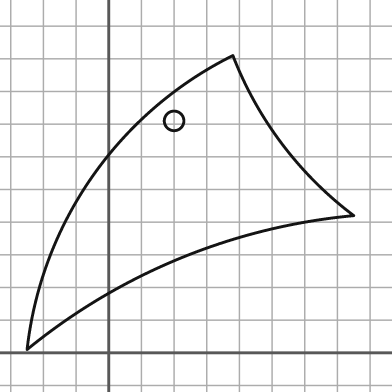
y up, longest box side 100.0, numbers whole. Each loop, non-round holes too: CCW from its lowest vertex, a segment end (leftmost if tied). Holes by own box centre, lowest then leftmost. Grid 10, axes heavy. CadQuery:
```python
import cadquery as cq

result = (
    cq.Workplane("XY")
    .moveTo(-25.0, 1.0)
    .threePointArc((22.0, 29.0), (75.0, 42.0))
    .threePointArc((53.0, 64.0), (38.0, 91.0))
    .threePointArc((-5.0, 54.0), (-25.0, 1.0))
    .close()
    .moveTo(20.0, 71.0)
    .circle(3.0)
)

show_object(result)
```